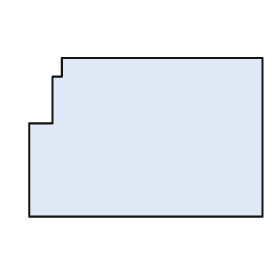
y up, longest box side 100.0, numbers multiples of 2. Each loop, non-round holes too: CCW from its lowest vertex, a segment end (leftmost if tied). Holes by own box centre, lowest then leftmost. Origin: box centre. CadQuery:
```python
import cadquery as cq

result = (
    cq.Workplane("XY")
    .moveTo(-50.0, -34.0)
    .lineTo(50.0, -34.0)
    .lineTo(50.0, 34.0)
    .lineTo(-36.0, 34.0)
    .lineTo(-36.0, 26.0)
    .lineTo(-40.0, 26.0)
    .lineTo(-40.0, 6.0)
    .lineTo(-50.0, 6.0)
    .close()
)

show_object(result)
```